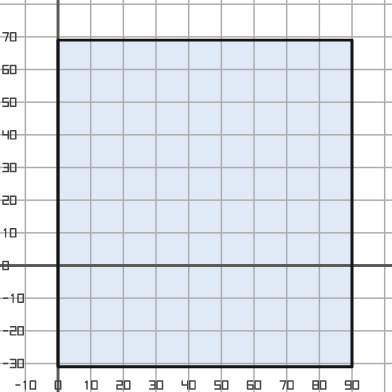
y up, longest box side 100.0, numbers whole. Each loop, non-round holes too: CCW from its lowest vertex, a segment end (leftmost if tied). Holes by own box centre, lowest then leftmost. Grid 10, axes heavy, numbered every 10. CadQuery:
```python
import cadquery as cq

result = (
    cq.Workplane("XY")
    .moveTo(0.0, -31.0)
    .lineTo(90.0, -31.0)
    .lineTo(90.0, 69.0)
    .lineTo(0.0, 69.0)
    .close()
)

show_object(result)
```